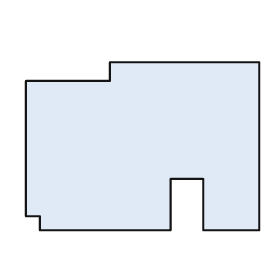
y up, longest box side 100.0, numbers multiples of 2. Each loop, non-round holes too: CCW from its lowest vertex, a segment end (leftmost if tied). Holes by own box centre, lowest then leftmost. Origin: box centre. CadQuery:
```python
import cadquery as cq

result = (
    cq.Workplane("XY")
    .moveTo(-44.0, -36.0)
    .lineTo(12.0, -36.0)
    .lineTo(12.0, -14.0)
    .lineTo(26.0, -14.0)
    .lineTo(26.0, -36.0)
    .lineTo(50.0, -36.0)
    .lineTo(50.0, 36.0)
    .lineTo(-14.0, 36.0)
    .lineTo(-14.0, 28.0)
    .lineTo(-50.0, 28.0)
    .lineTo(-50.0, -30.0)
    .lineTo(-44.0, -30.0)
    .close()
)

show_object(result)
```